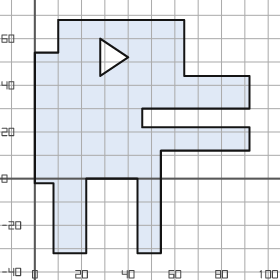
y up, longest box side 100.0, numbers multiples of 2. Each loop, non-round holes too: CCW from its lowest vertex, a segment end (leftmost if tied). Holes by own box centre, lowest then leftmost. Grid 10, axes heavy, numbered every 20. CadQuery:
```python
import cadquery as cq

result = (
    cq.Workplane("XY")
    .moveTo(8.0, -32.0)
    .lineTo(22.0, -32.0)
    .lineTo(22.0, 0.0)
    .lineTo(44.0, 0.0)
    .lineTo(44.0, -32.0)
    .lineTo(54.0, -32.0)
    .lineTo(54.0, 12.0)
    .lineTo(92.0, 12.0)
    .lineTo(92.0, 22.0)
    .lineTo(46.0, 22.0)
    .lineTo(46.0, 30.0)
    .lineTo(92.0, 30.0)
    .lineTo(92.0, 44.0)
    .lineTo(64.0, 44.0)
    .lineTo(64.0, 68.0)
    .lineTo(10.0, 68.0)
    .lineTo(10.0, 54.0)
    .lineTo(0.0, 54.0)
    .lineTo(0.0, -2.0)
    .lineTo(8.0, -2.0)
    .close()
    .moveTo(28.0, 44.0)
    .lineTo(40.0, 52.0)
    .lineTo(28.0, 60.0)
    .close()
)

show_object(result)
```